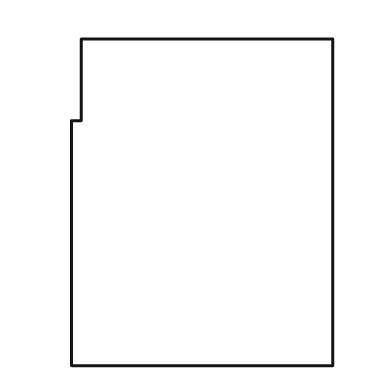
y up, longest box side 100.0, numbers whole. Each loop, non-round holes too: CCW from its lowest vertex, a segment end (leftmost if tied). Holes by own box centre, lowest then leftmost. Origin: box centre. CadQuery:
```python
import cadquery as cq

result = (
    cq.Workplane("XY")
    .moveTo(-40.0, -50.0)
    .lineTo(40.0, -50.0)
    .lineTo(40.0, 50.0)
    .lineTo(-37.0, 50.0)
    .lineTo(-37.0, 25.0)
    .lineTo(-40.0, 25.0)
    .close()
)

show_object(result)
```